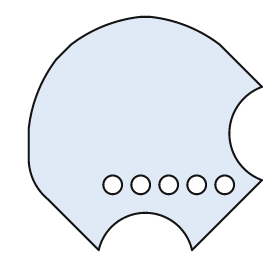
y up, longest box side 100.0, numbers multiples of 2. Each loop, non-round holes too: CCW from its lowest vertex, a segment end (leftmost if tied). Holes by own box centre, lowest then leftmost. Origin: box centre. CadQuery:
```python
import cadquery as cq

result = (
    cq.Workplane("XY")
    .moveTo(-20.0, -50.0)
    .threePointArc((0.0, -34.0), (20.0, -50.0))
    .lineTo(50.0, -20.0)
    .threePointArc((36.0, 0.0), (50.0, 20.0))
    .lineTo(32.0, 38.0)
    .threePointArc((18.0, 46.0), (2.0, 50.0))
    .lineTo(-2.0, 50.0)
    .threePointArc((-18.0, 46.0), (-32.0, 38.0))
    .lineTo(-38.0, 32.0)
    .threePointArc((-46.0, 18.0), (-50.0, 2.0))
    .lineTo(-50.0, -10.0)
    .threePointArc((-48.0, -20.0), (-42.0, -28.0))
    .close()
    .moveTo(-14.0, -22.0)
    .circle(4.0)
    .moveTo(-2.0, -22.0)
    .circle(4.0)
    .moveTo(10.0, -22.0)
    .circle(4.0)
    .moveTo(22.0, -22.0)
    .circle(4.0)
    .moveTo(34.0, -22.0)
    .circle(4.0)
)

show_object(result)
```